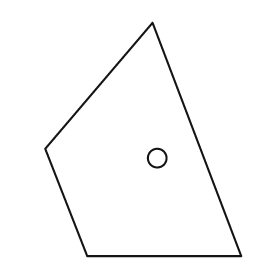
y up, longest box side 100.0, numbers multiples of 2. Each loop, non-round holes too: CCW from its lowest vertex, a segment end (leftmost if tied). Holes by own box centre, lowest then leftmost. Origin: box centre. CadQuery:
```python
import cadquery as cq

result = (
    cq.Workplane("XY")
    .moveTo(-24.0, -50.0)
    .lineTo(42.0, -50.0)
    .lineTo(4.0, 50.0)
    .lineTo(-42.0, -4.0)
    .close()
    .moveTo(6.0, -8.0)
    .circle(4.0)
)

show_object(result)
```